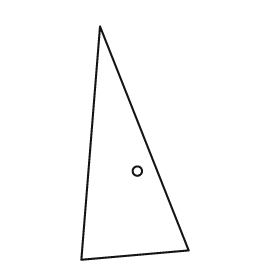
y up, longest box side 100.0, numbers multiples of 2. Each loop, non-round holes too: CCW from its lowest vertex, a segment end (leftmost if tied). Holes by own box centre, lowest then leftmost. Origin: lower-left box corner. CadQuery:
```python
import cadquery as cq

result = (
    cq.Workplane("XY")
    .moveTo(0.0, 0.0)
    .lineTo(46.0, 4.0)
    .lineTo(8.0, 100.0)
    .close()
    .moveTo(24.0, 38.0)
    .circle(2.0)
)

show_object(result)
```